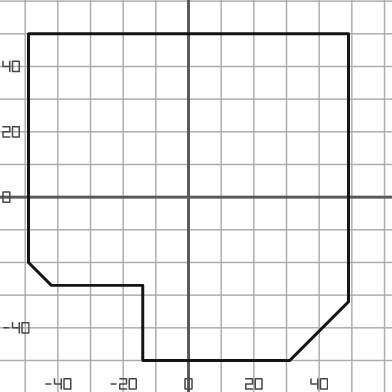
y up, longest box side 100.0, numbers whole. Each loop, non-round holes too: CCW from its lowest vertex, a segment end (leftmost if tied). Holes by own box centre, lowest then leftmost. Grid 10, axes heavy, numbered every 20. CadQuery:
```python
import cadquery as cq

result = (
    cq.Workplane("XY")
    .moveTo(-14.0, -50.0)
    .lineTo(31.0, -50.0)
    .lineTo(49.0, -32.0)
    .lineTo(49.0, 50.0)
    .lineTo(-49.0, 50.0)
    .lineTo(-49.0, -20.0)
    .lineTo(-42.0, -27.0)
    .lineTo(-14.0, -27.0)
    .close()
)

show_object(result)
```